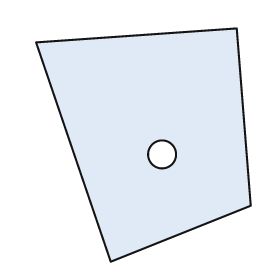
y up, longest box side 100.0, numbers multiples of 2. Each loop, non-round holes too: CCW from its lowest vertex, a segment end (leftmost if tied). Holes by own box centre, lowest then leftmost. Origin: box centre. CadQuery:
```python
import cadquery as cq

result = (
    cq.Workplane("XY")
    .moveTo(-14.0, -50.0)
    .lineTo(46.0, -26.0)
    .lineTo(40.0, 50.0)
    .lineTo(-46.0, 44.0)
    .close()
    .moveTo(8.0, -4.0)
    .circle(6.0)
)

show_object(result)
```